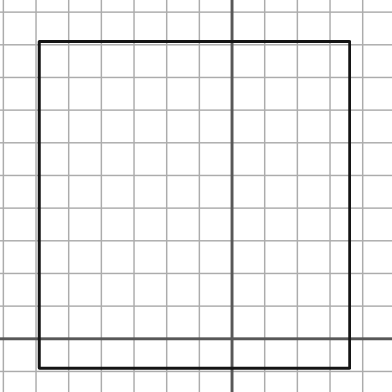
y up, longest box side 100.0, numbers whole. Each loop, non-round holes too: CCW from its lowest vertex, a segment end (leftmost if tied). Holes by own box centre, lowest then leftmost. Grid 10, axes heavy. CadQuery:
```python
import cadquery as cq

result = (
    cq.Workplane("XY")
    .moveTo(-59.0, -9.0)
    .lineTo(36.0, -9.0)
    .lineTo(36.0, 91.0)
    .lineTo(-59.0, 91.0)
    .close()
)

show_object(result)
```